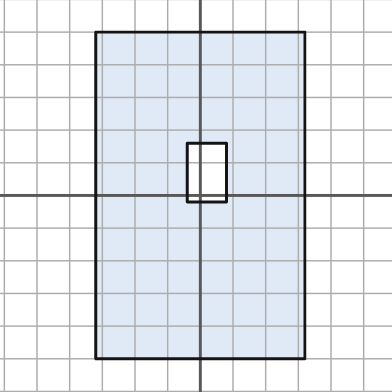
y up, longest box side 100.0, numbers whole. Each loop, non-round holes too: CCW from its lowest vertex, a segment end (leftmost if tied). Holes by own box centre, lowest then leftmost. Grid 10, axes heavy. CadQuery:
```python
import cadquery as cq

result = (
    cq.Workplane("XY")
    .moveTo(-32.0, -50.0)
    .lineTo(32.0, -50.0)
    .lineTo(32.0, 50.0)
    .lineTo(-32.0, 50.0)
    .close()
    .moveTo(-4.0, -2.0)
    .lineTo(8.0, -2.0)
    .lineTo(8.0, 16.0)
    .lineTo(-4.0, 16.0)
    .close()
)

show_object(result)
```